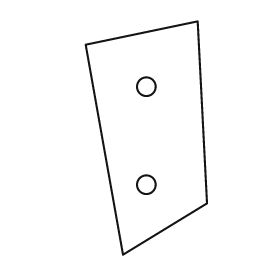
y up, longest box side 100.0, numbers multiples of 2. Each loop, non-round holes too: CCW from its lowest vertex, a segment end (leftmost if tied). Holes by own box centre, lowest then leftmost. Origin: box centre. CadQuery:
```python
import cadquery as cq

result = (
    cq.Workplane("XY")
    .moveTo(-10.0, -50.0)
    .lineTo(26.0, -28.0)
    .lineTo(22.0, 50.0)
    .lineTo(-26.0, 40.0)
    .close()
    .moveTo(0.0, -20.0)
    .circle(4.0)
    .moveTo(0.0, 22.0)
    .circle(4.0)
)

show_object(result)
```